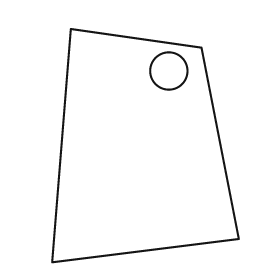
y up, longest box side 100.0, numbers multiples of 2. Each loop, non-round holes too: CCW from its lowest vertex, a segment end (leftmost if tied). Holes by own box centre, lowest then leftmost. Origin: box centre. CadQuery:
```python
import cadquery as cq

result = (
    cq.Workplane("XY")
    .moveTo(-40.0, -50.0)
    .lineTo(40.0, -40.0)
    .lineTo(24.0, 42.0)
    .lineTo(-32.0, 50.0)
    .close()
    .moveTo(10.0, 32.0)
    .circle(8.0)
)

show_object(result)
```